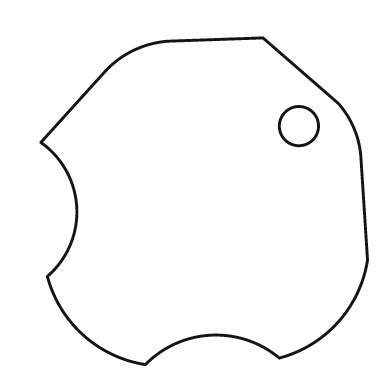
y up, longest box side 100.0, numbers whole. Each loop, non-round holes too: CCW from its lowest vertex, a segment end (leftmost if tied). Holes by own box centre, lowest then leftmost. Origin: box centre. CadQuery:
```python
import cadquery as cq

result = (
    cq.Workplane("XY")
    .moveTo(-18.0, -50.0)
    .threePointArc((2.0, -41.0), (23.0, -48.0))
    .threePointArc((41.0, -37.0), (50.0, -18.0))
    .lineTo(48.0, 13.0)
    .threePointArc((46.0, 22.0), (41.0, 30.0))
    .lineTo(18.0, 50.0)
    .lineTo(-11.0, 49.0)
    .threePointArc((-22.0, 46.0), (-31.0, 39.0))
    .lineTo(-50.0, 18.0)
    .threePointArc((-39.0, -2.0), (-48.0, -23.0))
    .threePointArc((-37.0, -41.0), (-18.0, -50.0))
    .close()
    .moveTo(29.0, 23.0)
    .circle(6.0)
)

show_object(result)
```